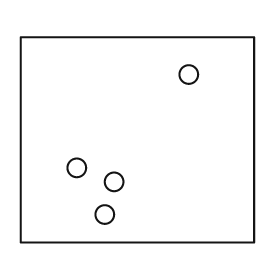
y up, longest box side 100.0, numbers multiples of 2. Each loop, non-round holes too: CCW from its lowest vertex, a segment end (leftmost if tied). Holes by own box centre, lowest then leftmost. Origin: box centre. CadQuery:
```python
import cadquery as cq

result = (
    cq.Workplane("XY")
    .moveTo(-50.0, -44.0)
    .lineTo(50.0, -44.0)
    .lineTo(50.0, 44.0)
    .lineTo(-50.0, 44.0)
    .close()
    .moveTo(-14.0, -32.0)
    .circle(4.0)
    .moveTo(-10.0, -18.0)
    .circle(4.0)
    .moveTo(-26.0, -12.0)
    .circle(4.0)
    .moveTo(22.0, 28.0)
    .circle(4.0)
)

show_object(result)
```